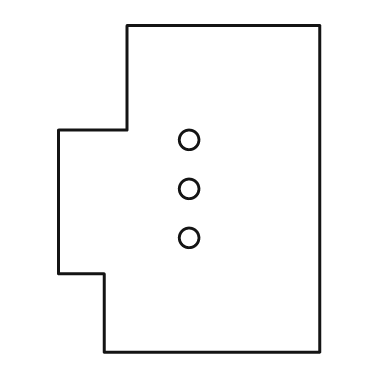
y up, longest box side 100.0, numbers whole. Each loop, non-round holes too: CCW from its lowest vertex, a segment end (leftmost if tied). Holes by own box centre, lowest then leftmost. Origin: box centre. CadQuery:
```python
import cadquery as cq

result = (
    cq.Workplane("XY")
    .moveTo(-26.0, -50.0)
    .lineTo(40.0, -50.0)
    .lineTo(40.0, 50.0)
    .lineTo(-19.0, 50.0)
    .lineTo(-19.0, 18.0)
    .lineTo(-40.0, 18.0)
    .lineTo(-40.0, -26.0)
    .lineTo(-26.0, -26.0)
    .close()
    .moveTo(0.0, -15.0)
    .circle(3.0)
    .moveTo(0.0, 0.0)
    .circle(3.0)
    .moveTo(0.0, 15.0)
    .circle(3.0)
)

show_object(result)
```